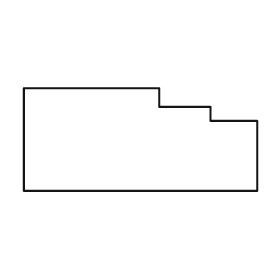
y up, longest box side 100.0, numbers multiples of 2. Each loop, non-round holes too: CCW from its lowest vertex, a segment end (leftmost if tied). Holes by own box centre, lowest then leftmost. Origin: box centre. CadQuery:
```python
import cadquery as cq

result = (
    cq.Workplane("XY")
    .moveTo(-50.0, -22.0)
    .lineTo(50.0, -22.0)
    .lineTo(50.0, 8.0)
    .lineTo(30.0, 8.0)
    .lineTo(30.0, 14.0)
    .lineTo(8.0, 14.0)
    .lineTo(8.0, 22.0)
    .lineTo(-50.0, 22.0)
    .close()
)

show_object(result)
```